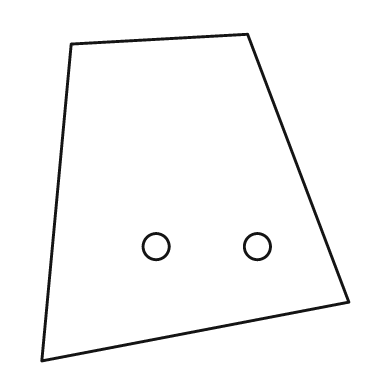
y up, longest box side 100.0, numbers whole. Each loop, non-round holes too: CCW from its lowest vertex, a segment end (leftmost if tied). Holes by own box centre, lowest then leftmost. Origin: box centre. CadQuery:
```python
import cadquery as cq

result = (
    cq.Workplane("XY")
    .moveTo(-47.0, -50.0)
    .lineTo(47.0, -32.0)
    .lineTo(16.0, 50.0)
    .lineTo(-38.0, 47.0)
    .close()
    .moveTo(-12.0, -15.0)
    .circle(4.0)
    .moveTo(19.0, -15.0)
    .circle(4.0)
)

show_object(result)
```